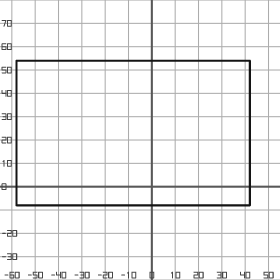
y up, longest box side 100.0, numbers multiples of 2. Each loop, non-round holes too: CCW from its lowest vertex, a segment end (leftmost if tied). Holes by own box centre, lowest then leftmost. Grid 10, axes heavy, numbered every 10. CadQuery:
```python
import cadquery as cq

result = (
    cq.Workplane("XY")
    .moveTo(-58.0, -8.0)
    .lineTo(42.0, -8.0)
    .lineTo(42.0, 54.0)
    .lineTo(-58.0, 54.0)
    .close()
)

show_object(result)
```